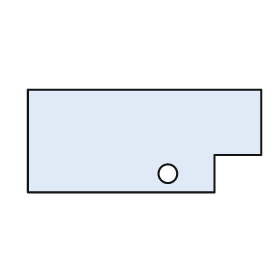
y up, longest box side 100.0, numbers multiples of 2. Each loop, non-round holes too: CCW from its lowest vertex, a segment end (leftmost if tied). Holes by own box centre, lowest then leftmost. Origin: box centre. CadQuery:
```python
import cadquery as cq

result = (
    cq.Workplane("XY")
    .moveTo(-50.0, -22.0)
    .lineTo(30.0, -22.0)
    .lineTo(30.0, -6.0)
    .lineTo(50.0, -6.0)
    .lineTo(50.0, 22.0)
    .lineTo(-50.0, 22.0)
    .close()
    .moveTo(10.0, -14.0)
    .circle(4.0)
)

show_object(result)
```